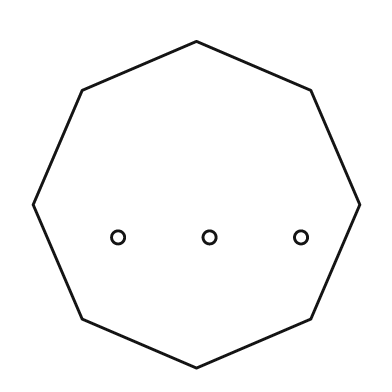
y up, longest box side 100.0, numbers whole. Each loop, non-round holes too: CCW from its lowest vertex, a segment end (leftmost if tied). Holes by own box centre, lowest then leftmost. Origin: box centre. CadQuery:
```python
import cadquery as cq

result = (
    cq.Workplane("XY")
    .moveTo(0.0, -50.0)
    .lineTo(35.0, -35.0)
    .lineTo(50.0, 0.0)
    .lineTo(35.0, 35.0)
    .lineTo(0.0, 50.0)
    .lineTo(-35.0, 35.0)
    .lineTo(-50.0, 0.0)
    .lineTo(-35.0, -35.0)
    .close()
    .moveTo(-24.0, -10.0)
    .circle(2.0)
    .moveTo(4.0, -10.0)
    .circle(2.0)
    .moveTo(32.0, -10.0)
    .circle(2.0)
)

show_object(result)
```